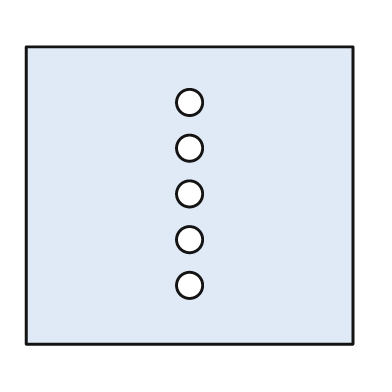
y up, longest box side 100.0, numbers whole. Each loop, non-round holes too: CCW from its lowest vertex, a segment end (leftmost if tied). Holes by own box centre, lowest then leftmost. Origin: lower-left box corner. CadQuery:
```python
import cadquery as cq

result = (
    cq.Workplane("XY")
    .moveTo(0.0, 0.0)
    .lineTo(100.0, 0.0)
    .lineTo(100.0, 91.0)
    .lineTo(0.0, 91.0)
    .close()
    .moveTo(50.0, 18.0)
    .circle(4.0)
    .moveTo(50.0, 32.0)
    .circle(4.0)
    .moveTo(50.0, 46.0)
    .circle(4.0)
    .moveTo(50.0, 60.0)
    .circle(4.0)
    .moveTo(50.0, 74.0)
    .circle(4.0)
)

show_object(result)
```